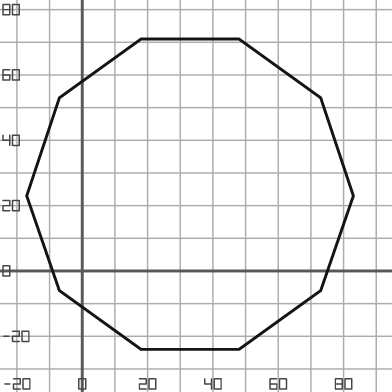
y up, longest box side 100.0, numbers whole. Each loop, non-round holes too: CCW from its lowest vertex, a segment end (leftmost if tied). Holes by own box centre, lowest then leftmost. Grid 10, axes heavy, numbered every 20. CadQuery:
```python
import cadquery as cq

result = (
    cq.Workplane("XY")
    .moveTo(18.0, -24.0)
    .lineTo(48.0, -24.0)
    .lineTo(73.0, -6.0)
    .lineTo(83.0, 23.0)
    .lineTo(73.0, 53.0)
    .lineTo(48.0, 71.0)
    .lineTo(18.0, 71.0)
    .lineTo(-7.0, 53.0)
    .lineTo(-17.0, 23.0)
    .lineTo(-7.0, -6.0)
    .close()
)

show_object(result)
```